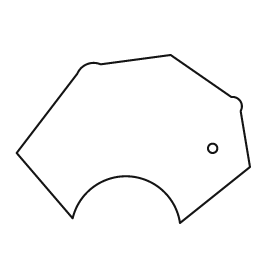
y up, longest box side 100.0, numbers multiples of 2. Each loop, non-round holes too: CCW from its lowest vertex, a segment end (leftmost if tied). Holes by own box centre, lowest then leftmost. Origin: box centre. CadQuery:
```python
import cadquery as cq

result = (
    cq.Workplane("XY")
    .moveTo(20.0, -36.0)
    .lineTo(50.0, -12.0)
    .lineTo(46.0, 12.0)
    .threePointArc((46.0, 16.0), (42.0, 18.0))
    .lineTo(16.0, 36.0)
    .lineTo(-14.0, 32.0)
    .threePointArc((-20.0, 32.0), (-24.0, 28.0))
    .lineTo(-50.0, -6.0)
    .lineTo(-26.0, -34.0)
    .threePointArc((-2.0, -16.0), (20.0, -36.0))
    .close()
    .moveTo(34.0, -4.0)
    .circle(2.0)
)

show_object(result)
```